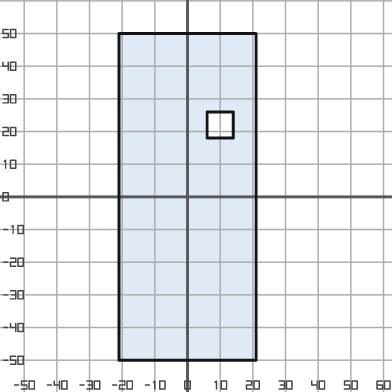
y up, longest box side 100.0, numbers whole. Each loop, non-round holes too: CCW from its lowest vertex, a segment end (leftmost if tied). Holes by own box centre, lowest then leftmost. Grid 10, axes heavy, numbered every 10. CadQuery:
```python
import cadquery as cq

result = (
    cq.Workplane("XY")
    .moveTo(-21.0, -50.0)
    .lineTo(21.0, -50.0)
    .lineTo(21.0, 50.0)
    .lineTo(-21.0, 50.0)
    .close()
    .moveTo(6.0, 18.0)
    .lineTo(14.0, 18.0)
    .lineTo(14.0, 26.0)
    .lineTo(6.0, 26.0)
    .close()
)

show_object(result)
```